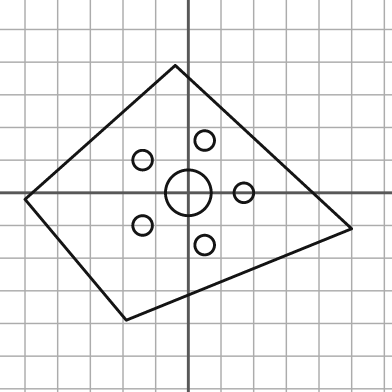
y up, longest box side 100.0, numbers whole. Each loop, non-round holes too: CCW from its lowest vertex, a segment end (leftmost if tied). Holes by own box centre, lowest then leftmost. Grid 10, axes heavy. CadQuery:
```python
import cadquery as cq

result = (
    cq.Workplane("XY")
    .moveTo(-19.0, -39.0)
    .lineTo(50.0, -11.0)
    .lineTo(-4.0, 39.0)
    .lineTo(-50.0, -2.0)
    .close()
    .moveTo(5.0, -16.0)
    .circle(3.0)
    .moveTo(-14.0, -10.0)
    .circle(3.0)
    .moveTo(0.0, 0.0)
    .circle(7.0)
    .moveTo(17.0, 0.0)
    .circle(3.0)
    .moveTo(-14.0, 10.0)
    .circle(3.0)
    .moveTo(5.0, 16.0)
    .circle(3.0)
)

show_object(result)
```